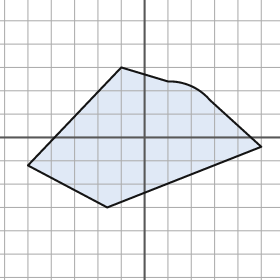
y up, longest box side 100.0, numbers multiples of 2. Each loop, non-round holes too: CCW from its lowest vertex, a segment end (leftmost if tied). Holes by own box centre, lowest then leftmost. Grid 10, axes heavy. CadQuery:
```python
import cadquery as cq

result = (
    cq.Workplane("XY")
    .moveTo(-16.0, -30.0)
    .lineTo(50.0, -4.0)
    .lineTo(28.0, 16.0)
    .threePointArc((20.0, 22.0), (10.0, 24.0))
    .lineTo(-10.0, 30.0)
    .lineTo(-50.0, -12.0)
    .close()
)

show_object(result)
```